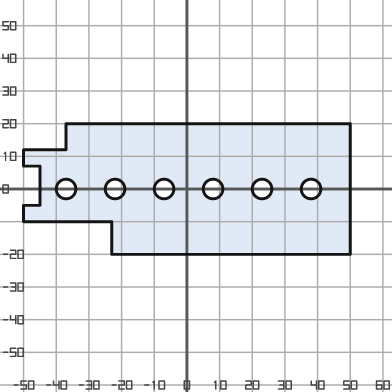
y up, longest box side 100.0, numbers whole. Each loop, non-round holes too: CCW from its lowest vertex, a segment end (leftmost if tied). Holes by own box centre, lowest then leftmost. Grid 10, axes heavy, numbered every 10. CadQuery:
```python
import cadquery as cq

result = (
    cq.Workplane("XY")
    .moveTo(-23.0, -20.0)
    .lineTo(50.0, -20.0)
    .lineTo(50.0, 20.0)
    .lineTo(-37.0, 20.0)
    .lineTo(-37.0, 12.0)
    .lineTo(-50.0, 12.0)
    .lineTo(-50.0, 7.0)
    .lineTo(-45.0, 7.0)
    .lineTo(-45.0, -5.0)
    .lineTo(-50.0, -5.0)
    .lineTo(-50.0, -10.0)
    .lineTo(-23.0, -10.0)
    .close()
    .moveTo(-37.0, 0.0)
    .circle(3.0)
    .moveTo(-22.0, 0.0)
    .circle(3.0)
    .moveTo(-7.0, 0.0)
    .circle(3.0)
    .moveTo(8.0, 0.0)
    .circle(3.0)
    .moveTo(23.0, 0.0)
    .circle(3.0)
    .moveTo(38.0, 0.0)
    .circle(3.0)
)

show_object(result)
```